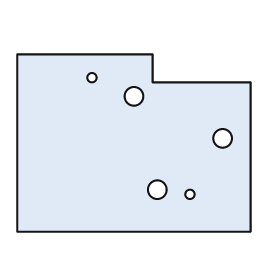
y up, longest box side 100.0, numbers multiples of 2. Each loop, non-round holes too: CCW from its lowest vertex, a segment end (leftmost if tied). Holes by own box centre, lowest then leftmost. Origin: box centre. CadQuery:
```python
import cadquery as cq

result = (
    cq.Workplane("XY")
    .moveTo(-50.0, -38.0)
    .lineTo(50.0, -38.0)
    .lineTo(50.0, 26.0)
    .lineTo(8.0, 26.0)
    .lineTo(8.0, 38.0)
    .lineTo(-50.0, 38.0)
    .close()
    .moveTo(24.0, -22.0)
    .circle(2.0)
    .moveTo(10.0, -20.0)
    .circle(4.0)
    .moveTo(38.0, 2.0)
    .circle(4.0)
    .moveTo(0.0, 20.0)
    .circle(4.0)
    .moveTo(-18.0, 28.0)
    .circle(2.0)
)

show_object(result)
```